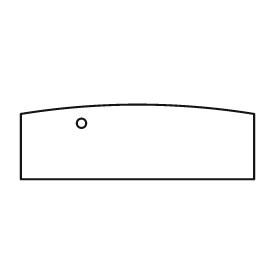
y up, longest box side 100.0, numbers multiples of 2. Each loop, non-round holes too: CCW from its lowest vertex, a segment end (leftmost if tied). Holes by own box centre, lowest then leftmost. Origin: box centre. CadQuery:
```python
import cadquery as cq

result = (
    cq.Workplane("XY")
    .moveTo(-50.0, -16.0)
    .lineTo(50.0, -16.0)
    .lineTo(50.0, 12.0)
    .threePointArc((0.0, 16.0), (-50.0, 12.0))
    .close()
    .moveTo(-24.0, 8.0)
    .circle(2.0)
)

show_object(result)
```